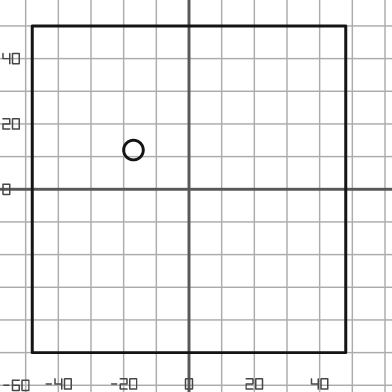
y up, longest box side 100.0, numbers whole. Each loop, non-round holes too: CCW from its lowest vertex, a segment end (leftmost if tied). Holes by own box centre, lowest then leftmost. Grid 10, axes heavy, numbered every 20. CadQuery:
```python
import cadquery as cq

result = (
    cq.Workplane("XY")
    .moveTo(-48.0, -50.0)
    .lineTo(48.0, -50.0)
    .lineTo(48.0, 50.0)
    .lineTo(-48.0, 50.0)
    .close()
    .moveTo(-17.0, 12.0)
    .circle(3.0)
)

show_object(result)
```